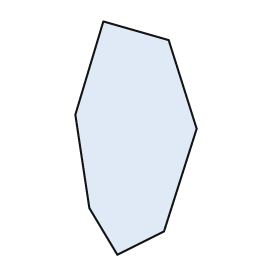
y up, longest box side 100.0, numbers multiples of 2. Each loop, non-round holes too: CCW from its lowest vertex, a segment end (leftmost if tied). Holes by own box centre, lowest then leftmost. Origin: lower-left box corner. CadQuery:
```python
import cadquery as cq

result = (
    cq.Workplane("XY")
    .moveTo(18.0, 0.0)
    .lineTo(38.0, 10.0)
    .lineTo(52.0, 54.0)
    .lineTo(40.0, 92.0)
    .lineTo(12.0, 100.0)
    .lineTo(0.0, 60.0)
    .lineTo(6.0, 20.0)
    .close()
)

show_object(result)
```